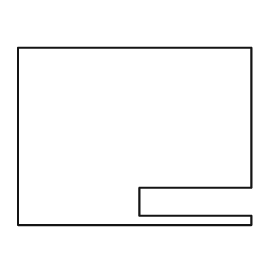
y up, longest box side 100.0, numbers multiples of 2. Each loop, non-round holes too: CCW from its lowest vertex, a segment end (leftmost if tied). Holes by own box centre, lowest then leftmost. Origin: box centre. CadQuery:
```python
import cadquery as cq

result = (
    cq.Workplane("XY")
    .moveTo(-50.0, -38.0)
    .lineTo(50.0, -38.0)
    .lineTo(50.0, -34.0)
    .lineTo(2.0, -34.0)
    .lineTo(2.0, -22.0)
    .lineTo(50.0, -22.0)
    .lineTo(50.0, 38.0)
    .lineTo(-50.0, 38.0)
    .close()
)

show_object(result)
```